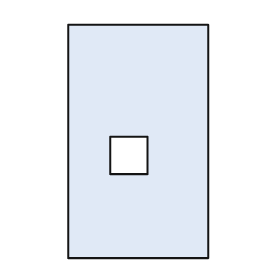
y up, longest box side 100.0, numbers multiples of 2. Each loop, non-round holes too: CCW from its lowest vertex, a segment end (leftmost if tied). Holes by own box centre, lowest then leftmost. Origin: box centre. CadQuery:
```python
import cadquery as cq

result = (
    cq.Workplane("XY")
    .moveTo(-30.0, -50.0)
    .lineTo(30.0, -50.0)
    .lineTo(30.0, 50.0)
    .lineTo(-30.0, 50.0)
    .close()
    .moveTo(-12.0, -14.0)
    .lineTo(4.0, -14.0)
    .lineTo(4.0, 2.0)
    .lineTo(-12.0, 2.0)
    .close()
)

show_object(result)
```